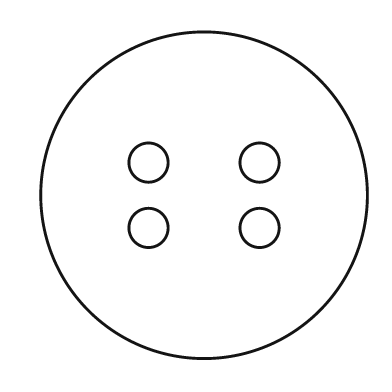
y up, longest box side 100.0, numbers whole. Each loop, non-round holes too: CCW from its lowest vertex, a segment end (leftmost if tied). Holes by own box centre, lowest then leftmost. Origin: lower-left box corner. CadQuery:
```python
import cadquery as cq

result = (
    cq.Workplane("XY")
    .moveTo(50.0, 50.0)
    .circle(50.0)
    .moveTo(33.0, 40.0)
    .circle(6.0)
    .moveTo(67.0, 40.0)
    .circle(6.0)
    .moveTo(33.0, 60.0)
    .circle(6.0)
    .moveTo(67.0, 60.0)
    .circle(6.0)
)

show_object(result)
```